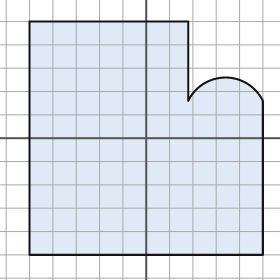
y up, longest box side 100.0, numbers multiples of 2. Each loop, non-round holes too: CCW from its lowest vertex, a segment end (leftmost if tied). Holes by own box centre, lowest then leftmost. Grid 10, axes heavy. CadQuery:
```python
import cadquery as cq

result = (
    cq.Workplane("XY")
    .moveTo(-50.0, -50.0)
    .lineTo(50.0, -50.0)
    .lineTo(50.0, 16.0)
    .threePointArc((34.0, 26.0), (18.0, 16.0))
    .lineTo(18.0, 50.0)
    .lineTo(-50.0, 50.0)
    .close()
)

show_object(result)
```